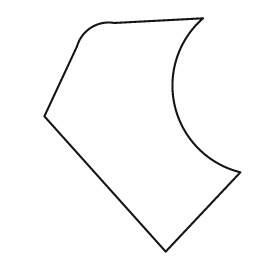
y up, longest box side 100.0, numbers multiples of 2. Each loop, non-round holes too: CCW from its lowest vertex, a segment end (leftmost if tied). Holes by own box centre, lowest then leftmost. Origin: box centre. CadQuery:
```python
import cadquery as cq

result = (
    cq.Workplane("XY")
    .moveTo(10.0, -50.0)
    .lineTo(42.0, -16.0)
    .threePointArc((14.0, 12.0), (26.0, 50.0))
    .lineTo(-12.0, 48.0)
    .threePointArc((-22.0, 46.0), (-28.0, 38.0))
    .lineTo(-42.0, 8.0)
    .close()
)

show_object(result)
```